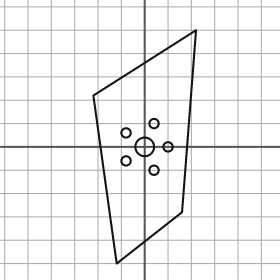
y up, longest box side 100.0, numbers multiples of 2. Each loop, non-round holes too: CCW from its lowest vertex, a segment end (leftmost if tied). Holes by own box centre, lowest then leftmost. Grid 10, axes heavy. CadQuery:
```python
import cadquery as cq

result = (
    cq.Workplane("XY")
    .moveTo(-12.0, -50.0)
    .lineTo(16.0, -28.0)
    .lineTo(22.0, 50.0)
    .lineTo(-22.0, 22.0)
    .close()
    .moveTo(4.0, -10.0)
    .circle(2.0)
    .moveTo(-8.0, -6.0)
    .circle(2.0)
    .moveTo(0.0, 0.0)
    .circle(4.0)
    .moveTo(10.0, 0.0)
    .circle(2.0)
    .moveTo(-8.0, 6.0)
    .circle(2.0)
    .moveTo(4.0, 10.0)
    .circle(2.0)
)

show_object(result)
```